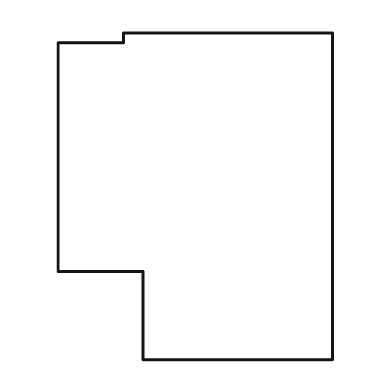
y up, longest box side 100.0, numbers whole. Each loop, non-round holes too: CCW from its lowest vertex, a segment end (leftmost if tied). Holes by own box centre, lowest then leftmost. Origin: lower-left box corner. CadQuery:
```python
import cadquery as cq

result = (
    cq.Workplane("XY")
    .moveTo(26.0, 0.0)
    .lineTo(84.0, 0.0)
    .lineTo(84.0, 100.0)
    .lineTo(20.0, 100.0)
    .lineTo(20.0, 97.0)
    .lineTo(0.0, 97.0)
    .lineTo(0.0, 27.0)
    .lineTo(26.0, 27.0)
    .close()
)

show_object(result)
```